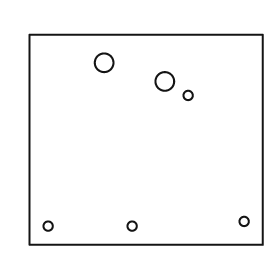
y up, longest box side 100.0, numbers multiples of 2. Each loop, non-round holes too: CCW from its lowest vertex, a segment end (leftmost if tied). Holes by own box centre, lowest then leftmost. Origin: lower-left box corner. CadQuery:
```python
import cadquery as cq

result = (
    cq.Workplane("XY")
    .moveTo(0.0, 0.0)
    .lineTo(100.0, 0.0)
    .lineTo(100.0, 90.0)
    .lineTo(0.0, 90.0)
    .close()
    .moveTo(8.0, 8.0)
    .circle(2.0)
    .moveTo(44.0, 8.0)
    .circle(2.0)
    .moveTo(92.0, 10.0)
    .circle(2.0)
    .moveTo(68.0, 64.0)
    .circle(2.0)
    .moveTo(58.0, 70.0)
    .circle(4.0)
    .moveTo(32.0, 78.0)
    .circle(4.0)
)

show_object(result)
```